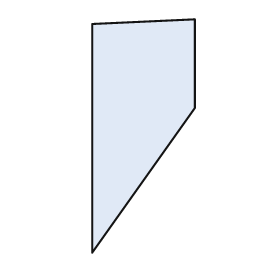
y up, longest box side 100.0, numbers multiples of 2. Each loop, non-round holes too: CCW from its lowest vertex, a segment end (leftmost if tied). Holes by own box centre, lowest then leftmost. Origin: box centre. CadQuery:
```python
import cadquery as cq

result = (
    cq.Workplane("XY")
    .moveTo(-22.0, -50.0)
    .lineTo(22.0, 12.0)
    .lineTo(22.0, 50.0)
    .lineTo(-22.0, 48.0)
    .close()
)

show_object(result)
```